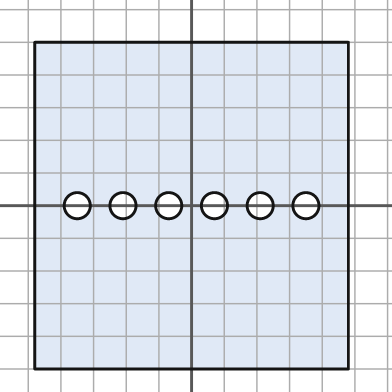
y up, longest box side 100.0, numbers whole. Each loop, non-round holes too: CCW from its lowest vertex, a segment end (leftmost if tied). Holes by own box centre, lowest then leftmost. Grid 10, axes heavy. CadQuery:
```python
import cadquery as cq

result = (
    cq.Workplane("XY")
    .moveTo(-48.0, -50.0)
    .lineTo(48.0, -50.0)
    .lineTo(48.0, 50.0)
    .lineTo(-48.0, 50.0)
    .close()
    .moveTo(-35.0, 0.0)
    .circle(4.0)
    .moveTo(-21.0, 0.0)
    .circle(4.0)
    .moveTo(-7.0, 0.0)
    .circle(4.0)
    .moveTo(7.0, 0.0)
    .circle(4.0)
    .moveTo(21.0, 0.0)
    .circle(4.0)
    .moveTo(35.0, 0.0)
    .circle(4.0)
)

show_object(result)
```